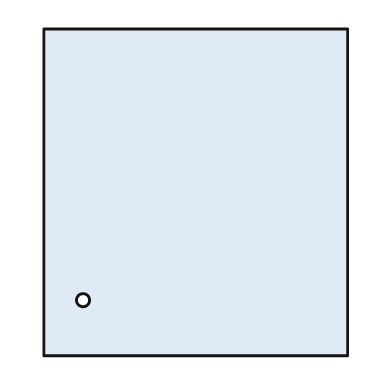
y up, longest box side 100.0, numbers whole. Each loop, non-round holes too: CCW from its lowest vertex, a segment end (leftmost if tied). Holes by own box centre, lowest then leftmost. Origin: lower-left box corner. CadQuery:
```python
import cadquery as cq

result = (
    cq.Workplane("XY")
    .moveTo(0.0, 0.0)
    .lineTo(93.0, 0.0)
    .lineTo(93.0, 100.0)
    .lineTo(0.0, 100.0)
    .close()
    .moveTo(12.0, 17.0)
    .circle(2.0)
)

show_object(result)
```